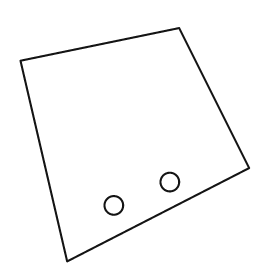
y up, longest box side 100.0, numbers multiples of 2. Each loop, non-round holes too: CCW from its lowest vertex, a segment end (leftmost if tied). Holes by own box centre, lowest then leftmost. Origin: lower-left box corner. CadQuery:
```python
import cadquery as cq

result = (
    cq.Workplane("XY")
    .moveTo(20.0, 0.0)
    .lineTo(98.0, 40.0)
    .lineTo(68.0, 100.0)
    .lineTo(0.0, 86.0)
    .close()
    .moveTo(40.0, 24.0)
    .circle(4.0)
    .moveTo(64.0, 34.0)
    .circle(4.0)
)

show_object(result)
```